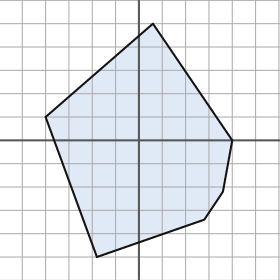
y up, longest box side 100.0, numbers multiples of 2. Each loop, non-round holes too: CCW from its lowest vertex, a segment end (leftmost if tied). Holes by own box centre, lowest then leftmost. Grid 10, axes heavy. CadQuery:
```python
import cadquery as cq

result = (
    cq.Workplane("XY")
    .moveTo(-18.0, -50.0)
    .lineTo(28.0, -34.0)
    .lineTo(36.0, -22.0)
    .lineTo(40.0, 0.0)
    .lineTo(6.0, 50.0)
    .lineTo(-40.0, 10.0)
    .close()
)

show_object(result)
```